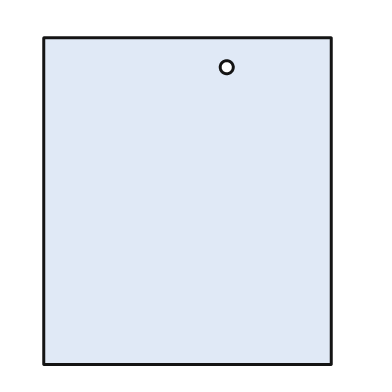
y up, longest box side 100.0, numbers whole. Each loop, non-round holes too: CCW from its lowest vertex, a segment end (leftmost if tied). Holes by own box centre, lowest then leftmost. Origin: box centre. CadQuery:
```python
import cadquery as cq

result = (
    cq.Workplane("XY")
    .moveTo(-44.0, -50.0)
    .lineTo(44.0, -50.0)
    .lineTo(44.0, 50.0)
    .lineTo(-44.0, 50.0)
    .close()
    .moveTo(12.0, 41.0)
    .circle(2.0)
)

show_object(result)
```